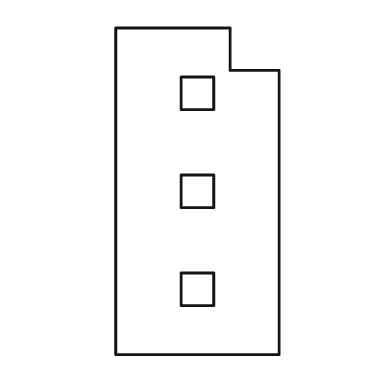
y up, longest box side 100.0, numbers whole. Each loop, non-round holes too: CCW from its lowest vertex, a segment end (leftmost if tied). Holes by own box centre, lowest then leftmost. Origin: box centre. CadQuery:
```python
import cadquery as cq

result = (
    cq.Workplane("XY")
    .moveTo(-25.0, -50.0)
    .lineTo(25.0, -50.0)
    .lineTo(25.0, 37.0)
    .lineTo(10.0, 37.0)
    .lineTo(10.0, 50.0)
    .lineTo(-25.0, 50.0)
    .close()
    .moveTo(-5.0, -35.0)
    .lineTo(5.0, -35.0)
    .lineTo(5.0, -25.0)
    .lineTo(-5.0, -25.0)
    .close()
    .moveTo(-5.0, -5.0)
    .lineTo(5.0, -5.0)
    .lineTo(5.0, 5.0)
    .lineTo(-5.0, 5.0)
    .close()
    .moveTo(-5.0, 25.0)
    .lineTo(5.0, 25.0)
    .lineTo(5.0, 35.0)
    .lineTo(-5.0, 35.0)
    .close()
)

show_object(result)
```